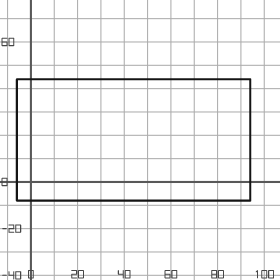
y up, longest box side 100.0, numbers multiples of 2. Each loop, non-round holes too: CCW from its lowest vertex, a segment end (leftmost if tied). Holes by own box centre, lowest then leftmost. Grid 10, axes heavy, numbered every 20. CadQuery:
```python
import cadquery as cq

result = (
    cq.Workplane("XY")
    .moveTo(-6.0, -8.0)
    .lineTo(94.0, -8.0)
    .lineTo(94.0, 44.0)
    .lineTo(-6.0, 44.0)
    .close()
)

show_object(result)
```